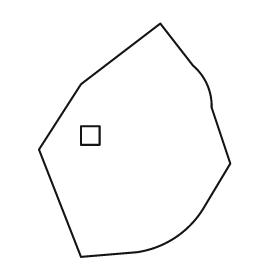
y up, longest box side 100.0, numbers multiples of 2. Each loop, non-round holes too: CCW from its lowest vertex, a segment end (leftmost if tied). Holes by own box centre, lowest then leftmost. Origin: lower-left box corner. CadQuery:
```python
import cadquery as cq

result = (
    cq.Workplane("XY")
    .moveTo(18.0, 0.0)
    .lineTo(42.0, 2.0)
    .threePointArc((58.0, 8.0), (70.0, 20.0))
    .lineTo(82.0, 40.0)
    .lineTo(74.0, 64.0)
    .threePointArc((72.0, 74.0), (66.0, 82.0))
    .lineTo(52.0, 100.0)
    .lineTo(18.0, 74.0)
    .lineTo(0.0, 46.0)
    .close()
    .moveTo(18.0, 48.0)
    .lineTo(26.0, 48.0)
    .lineTo(26.0, 56.0)
    .lineTo(18.0, 56.0)
    .close()
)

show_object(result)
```